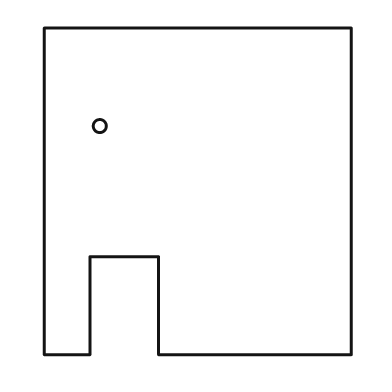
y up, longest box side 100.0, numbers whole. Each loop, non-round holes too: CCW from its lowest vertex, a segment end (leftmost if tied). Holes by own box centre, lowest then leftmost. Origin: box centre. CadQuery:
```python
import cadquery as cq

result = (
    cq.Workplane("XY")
    .moveTo(-47.0, -50.0)
    .lineTo(-33.0, -50.0)
    .lineTo(-33.0, -20.0)
    .lineTo(-12.0, -20.0)
    .lineTo(-12.0, -50.0)
    .lineTo(47.0, -50.0)
    .lineTo(47.0, 50.0)
    .lineTo(-47.0, 50.0)
    .close()
    .moveTo(-30.0, 20.0)
    .circle(2.0)
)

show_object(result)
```